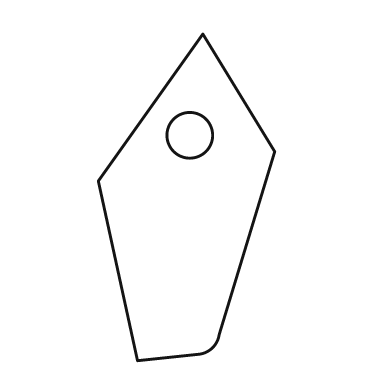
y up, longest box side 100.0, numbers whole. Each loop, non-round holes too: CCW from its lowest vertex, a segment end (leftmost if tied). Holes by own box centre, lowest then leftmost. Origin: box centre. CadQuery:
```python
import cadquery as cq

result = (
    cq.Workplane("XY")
    .moveTo(-15.0, -50.0)
    .lineTo(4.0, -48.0)
    .threePointArc((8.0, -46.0), (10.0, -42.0))
    .lineTo(27.0, 14.0)
    .lineTo(5.0, 50.0)
    .lineTo(-27.0, 5.0)
    .close()
    .moveTo(1.0, 19.0)
    .circle(7.0)
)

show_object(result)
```